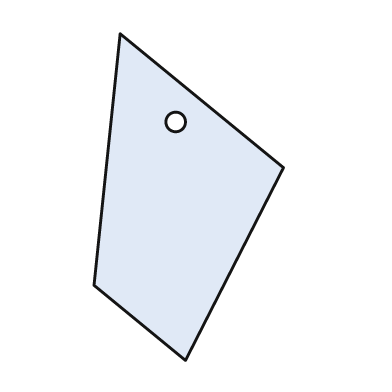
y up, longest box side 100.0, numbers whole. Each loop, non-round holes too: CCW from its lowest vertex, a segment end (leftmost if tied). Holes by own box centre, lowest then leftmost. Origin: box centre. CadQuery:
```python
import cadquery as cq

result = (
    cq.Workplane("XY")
    .moveTo(-1.0, -50.0)
    .lineTo(29.0, 9.0)
    .lineTo(-21.0, 50.0)
    .lineTo(-29.0, -27.0)
    .close()
    .moveTo(-4.0, 23.0)
    .circle(3.0)
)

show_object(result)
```